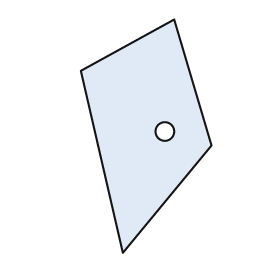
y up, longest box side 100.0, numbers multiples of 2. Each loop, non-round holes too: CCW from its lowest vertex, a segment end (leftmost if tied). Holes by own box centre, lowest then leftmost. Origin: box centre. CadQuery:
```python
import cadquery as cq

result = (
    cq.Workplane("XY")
    .moveTo(-10.0, -50.0)
    .lineTo(28.0, -4.0)
    .lineTo(12.0, 50.0)
    .lineTo(-28.0, 28.0)
    .close()
    .moveTo(8.0, 2.0)
    .circle(4.0)
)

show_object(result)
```